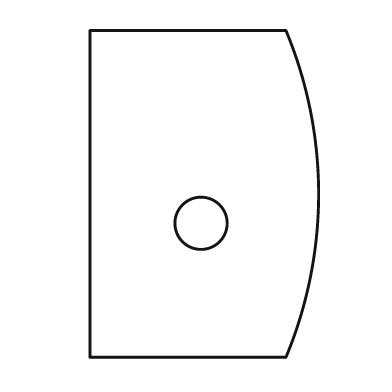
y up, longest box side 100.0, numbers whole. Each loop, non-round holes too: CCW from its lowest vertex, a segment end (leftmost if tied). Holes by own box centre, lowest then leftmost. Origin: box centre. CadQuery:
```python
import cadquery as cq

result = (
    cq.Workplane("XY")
    .moveTo(-35.0, -50.0)
    .lineTo(25.0, -50.0)
    .threePointArc((35.0, 0.0), (25.0, 50.0))
    .lineTo(-35.0, 50.0)
    .close()
    .moveTo(-1.0, -9.0)
    .circle(8.0)
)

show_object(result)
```